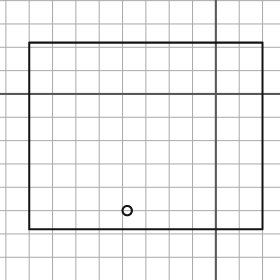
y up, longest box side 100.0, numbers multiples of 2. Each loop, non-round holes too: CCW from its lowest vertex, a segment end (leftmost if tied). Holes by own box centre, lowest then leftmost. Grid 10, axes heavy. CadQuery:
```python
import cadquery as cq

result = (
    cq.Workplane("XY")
    .moveTo(-80.0, -58.0)
    .lineTo(20.0, -58.0)
    .lineTo(20.0, 22.0)
    .lineTo(-80.0, 22.0)
    .close()
    .moveTo(-38.0, -50.0)
    .circle(2.0)
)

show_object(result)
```